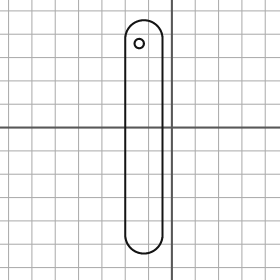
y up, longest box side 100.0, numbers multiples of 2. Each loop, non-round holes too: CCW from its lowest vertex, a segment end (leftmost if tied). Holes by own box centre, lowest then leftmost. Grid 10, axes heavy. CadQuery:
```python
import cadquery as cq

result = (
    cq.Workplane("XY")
    .moveTo(-20.0, -46.0)
    .threePointArc((-12.0, -54.0), (-4.0, -46.0))
    .lineTo(-4.0, 38.0)
    .threePointArc((-12.0, 46.0), (-20.0, 38.0))
    .close()
    .moveTo(-14.0, 36.0)
    .circle(2.0)
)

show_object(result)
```